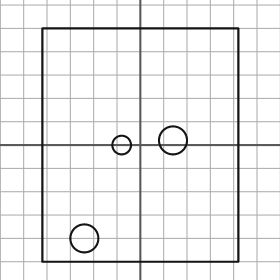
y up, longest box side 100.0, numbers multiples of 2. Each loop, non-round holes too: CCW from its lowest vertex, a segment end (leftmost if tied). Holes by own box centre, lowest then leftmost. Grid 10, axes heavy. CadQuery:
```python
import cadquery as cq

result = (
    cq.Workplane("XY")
    .moveTo(-42.0, -50.0)
    .lineTo(42.0, -50.0)
    .lineTo(42.0, 50.0)
    .lineTo(-42.0, 50.0)
    .close()
    .moveTo(-24.0, -40.0)
    .circle(6.0)
    .moveTo(-8.0, 0.0)
    .circle(4.0)
    .moveTo(14.0, 2.0)
    .circle(6.0)
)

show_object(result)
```